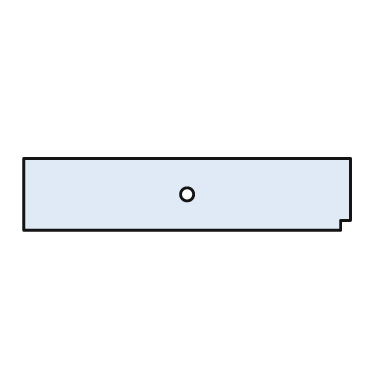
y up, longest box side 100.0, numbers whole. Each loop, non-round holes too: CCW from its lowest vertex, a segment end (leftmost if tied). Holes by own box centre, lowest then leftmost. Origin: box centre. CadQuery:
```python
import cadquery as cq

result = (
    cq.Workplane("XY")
    .moveTo(-50.0, -11.0)
    .lineTo(47.0, -11.0)
    .lineTo(47.0, -8.0)
    .lineTo(50.0, -8.0)
    .lineTo(50.0, 11.0)
    .lineTo(-50.0, 11.0)
    .close()
    .moveTo(0.0, 0.0)
    .circle(2.0)
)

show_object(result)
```